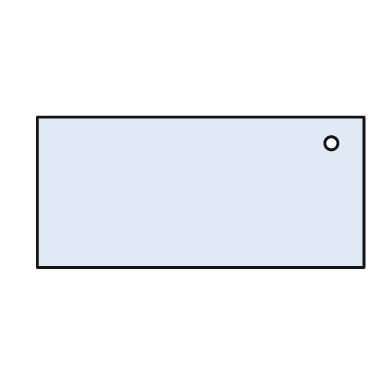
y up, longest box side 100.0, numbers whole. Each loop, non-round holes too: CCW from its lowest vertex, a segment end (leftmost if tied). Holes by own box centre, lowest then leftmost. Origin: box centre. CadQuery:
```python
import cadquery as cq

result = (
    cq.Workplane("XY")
    .moveTo(-50.0, -23.0)
    .lineTo(50.0, -23.0)
    .lineTo(50.0, 23.0)
    .lineTo(-50.0, 23.0)
    .close()
    .moveTo(40.0, 15.0)
    .circle(2.0)
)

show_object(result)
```